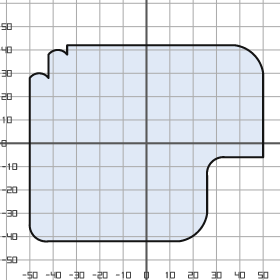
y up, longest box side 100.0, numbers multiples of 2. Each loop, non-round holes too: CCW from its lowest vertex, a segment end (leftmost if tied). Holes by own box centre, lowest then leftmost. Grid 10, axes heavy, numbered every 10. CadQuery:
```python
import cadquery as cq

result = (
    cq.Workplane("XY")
    .moveTo(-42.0, -42.0)
    .lineTo(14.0, -42.0)
    .threePointArc((22.0, -38.0), (26.0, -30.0))
    .lineTo(26.0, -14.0)
    .threePointArc((28.0, -8.0), (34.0, -6.0))
    .lineTo(50.0, -6.0)
    .lineTo(50.0, 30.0)
    .threePointArc((46.0, 38.0), (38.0, 42.0))
    .lineTo(-34.0, 42.0)
    .lineTo(-34.0, 38.0)
    .threePointArc((-38.0, 40.0), (-42.0, 38.0))
    .lineTo(-42.0, 28.0)
    .threePointArc((-46.0, 30.0), (-50.0, 28.0))
    .lineTo(-50.0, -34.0)
    .threePointArc((-48.0, -40.0), (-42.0, -42.0))
    .close()
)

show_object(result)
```